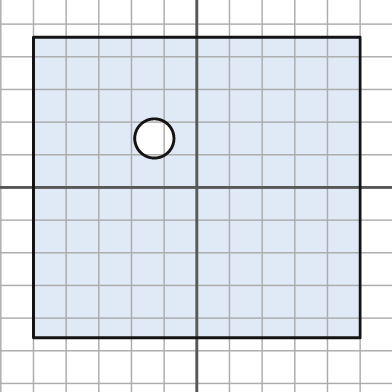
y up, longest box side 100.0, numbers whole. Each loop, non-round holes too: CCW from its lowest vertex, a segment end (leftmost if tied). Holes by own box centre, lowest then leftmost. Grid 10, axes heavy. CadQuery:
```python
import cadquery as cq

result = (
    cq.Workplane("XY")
    .moveTo(-50.0, -46.0)
    .lineTo(50.0, -46.0)
    .lineTo(50.0, 46.0)
    .lineTo(-50.0, 46.0)
    .close()
    .moveTo(-13.0, 15.0)
    .circle(6.0)
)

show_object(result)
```